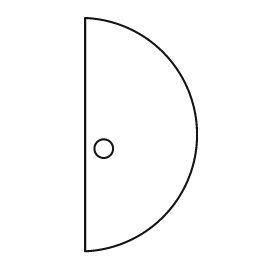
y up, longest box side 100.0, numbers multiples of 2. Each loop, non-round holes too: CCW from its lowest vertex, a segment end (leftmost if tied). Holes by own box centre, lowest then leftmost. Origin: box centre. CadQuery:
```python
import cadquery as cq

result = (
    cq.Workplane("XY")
    .moveTo(-24.0, -50.0)
    .threePointArc((24.0, 0.0), (-24.0, 50.0))
    .close()
    .moveTo(-16.0, -6.0)
    .circle(4.0)
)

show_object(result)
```